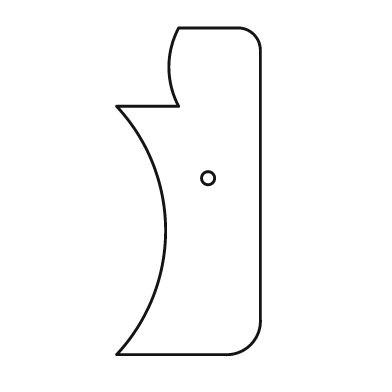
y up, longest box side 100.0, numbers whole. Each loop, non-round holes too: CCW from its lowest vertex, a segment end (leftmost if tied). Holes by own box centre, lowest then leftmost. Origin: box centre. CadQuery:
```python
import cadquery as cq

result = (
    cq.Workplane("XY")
    .moveTo(-22.0, -50.0)
    .lineTo(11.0, -50.0)
    .threePointArc((19.0, -47.0), (22.0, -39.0))
    .lineTo(22.0, 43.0)
    .threePointArc((20.0, 48.0), (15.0, 50.0))
    .lineTo(-3.0, 50.0)
    .threePointArc((-6.0, 38.0), (-3.0, 26.0))
    .lineTo(-22.0, 26.0)
    .threePointArc((-7.0, -12.0), (-22.0, -50.0))
    .close()
    .moveTo(6.0, 4.0)
    .circle(2.0)
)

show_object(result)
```